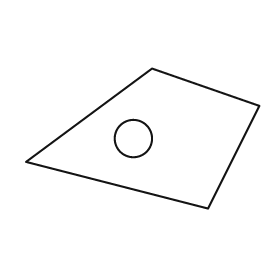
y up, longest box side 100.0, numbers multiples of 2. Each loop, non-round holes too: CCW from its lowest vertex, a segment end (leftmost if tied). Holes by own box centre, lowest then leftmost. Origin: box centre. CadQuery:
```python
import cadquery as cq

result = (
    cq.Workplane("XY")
    .moveTo(28.0, -30.0)
    .lineTo(50.0, 14.0)
    .lineTo(4.0, 30.0)
    .lineTo(-50.0, -10.0)
    .close()
    .moveTo(-4.0, 0.0)
    .circle(8.0)
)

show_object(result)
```